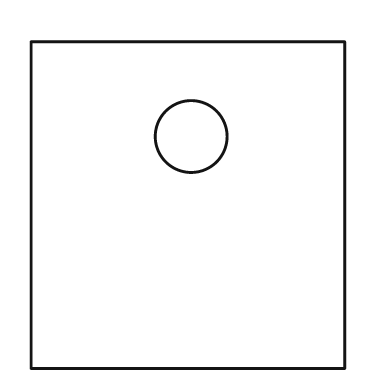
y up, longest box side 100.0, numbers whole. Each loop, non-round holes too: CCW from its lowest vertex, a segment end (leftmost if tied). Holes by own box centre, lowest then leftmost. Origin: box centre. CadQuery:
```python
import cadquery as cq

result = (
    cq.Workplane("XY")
    .moveTo(-48.0, -50.0)
    .lineTo(48.0, -50.0)
    .lineTo(48.0, 50.0)
    .lineTo(-48.0, 50.0)
    .close()
    .moveTo(1.0, 21.0)
    .circle(11.0)
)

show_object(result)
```